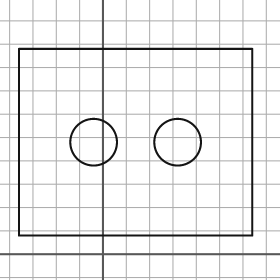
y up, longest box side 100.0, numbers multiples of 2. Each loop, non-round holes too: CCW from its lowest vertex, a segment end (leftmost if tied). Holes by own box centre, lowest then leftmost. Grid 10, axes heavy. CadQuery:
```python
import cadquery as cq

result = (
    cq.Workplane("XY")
    .moveTo(-36.0, 8.0)
    .lineTo(64.0, 8.0)
    .lineTo(64.0, 88.0)
    .lineTo(-36.0, 88.0)
    .close()
    .moveTo(-4.0, 48.0)
    .circle(10.0)
    .moveTo(32.0, 48.0)
    .circle(10.0)
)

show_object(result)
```